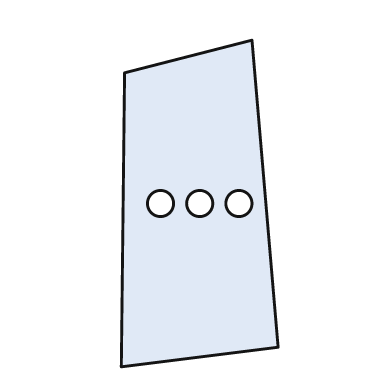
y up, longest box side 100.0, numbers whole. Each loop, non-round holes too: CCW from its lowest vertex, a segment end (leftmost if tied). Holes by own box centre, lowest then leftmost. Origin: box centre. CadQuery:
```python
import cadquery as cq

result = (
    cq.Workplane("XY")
    .moveTo(-24.0, -50.0)
    .lineTo(24.0, -44.0)
    .lineTo(16.0, 50.0)
    .lineTo(-23.0, 40.0)
    .close()
    .moveTo(-12.0, 0.0)
    .circle(4.0)
    .moveTo(0.0, 0.0)
    .circle(4.0)
    .moveTo(12.0, 0.0)
    .circle(4.0)
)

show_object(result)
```